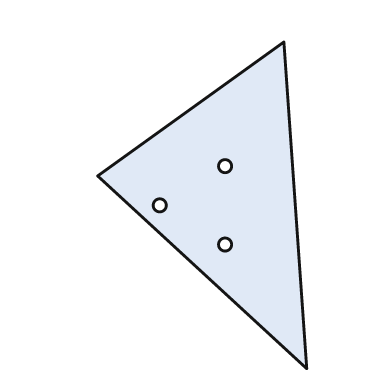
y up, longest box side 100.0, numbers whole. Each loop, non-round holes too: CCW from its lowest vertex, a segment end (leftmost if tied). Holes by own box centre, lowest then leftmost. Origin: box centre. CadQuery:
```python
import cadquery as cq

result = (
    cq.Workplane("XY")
    .moveTo(32.0, -50.0)
    .lineTo(25.0, 50.0)
    .lineTo(-32.0, 9.0)
    .close()
    .moveTo(7.0, -12.0)
    .circle(2.0)
    .moveTo(-13.0, 0.0)
    .circle(2.0)
    .moveTo(7.0, 12.0)
    .circle(2.0)
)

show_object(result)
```